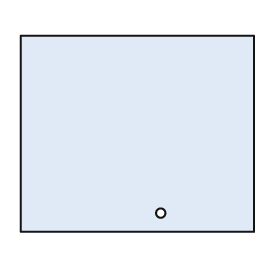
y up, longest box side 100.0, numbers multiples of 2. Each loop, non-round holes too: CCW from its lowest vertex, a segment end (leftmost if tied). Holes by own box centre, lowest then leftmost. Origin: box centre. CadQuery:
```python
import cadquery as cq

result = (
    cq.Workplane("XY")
    .moveTo(-50.0, -42.0)
    .lineTo(50.0, -42.0)
    .lineTo(50.0, 42.0)
    .lineTo(-50.0, 42.0)
    .close()
    .moveTo(10.0, -34.0)
    .circle(2.0)
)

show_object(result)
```